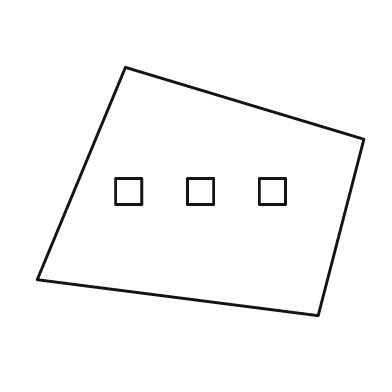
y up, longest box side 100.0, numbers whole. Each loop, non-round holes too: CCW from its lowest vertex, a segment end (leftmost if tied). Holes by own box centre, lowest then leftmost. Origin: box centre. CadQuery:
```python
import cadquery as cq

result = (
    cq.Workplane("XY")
    .moveTo(36.0, -38.0)
    .lineTo(50.0, 16.0)
    .lineTo(-23.0, 38.0)
    .lineTo(-50.0, -27.0)
    .close()
    .moveTo(-26.0, -4.0)
    .lineTo(-18.0, -4.0)
    .lineTo(-18.0, 4.0)
    .lineTo(-26.0, 4.0)
    .close()
    .moveTo(-4.0, -4.0)
    .lineTo(4.0, -4.0)
    .lineTo(4.0, 4.0)
    .lineTo(-4.0, 4.0)
    .close()
    .moveTo(18.0, -4.0)
    .lineTo(26.0, -4.0)
    .lineTo(26.0, 4.0)
    .lineTo(18.0, 4.0)
    .close()
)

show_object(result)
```